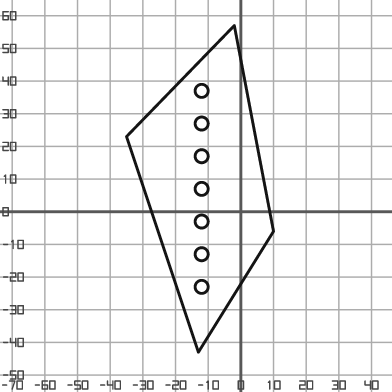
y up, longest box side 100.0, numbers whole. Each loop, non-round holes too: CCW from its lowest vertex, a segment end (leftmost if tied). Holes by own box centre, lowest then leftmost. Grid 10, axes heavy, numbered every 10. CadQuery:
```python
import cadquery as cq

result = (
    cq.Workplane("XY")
    .moveTo(-13.0, -43.0)
    .lineTo(10.0, -6.0)
    .lineTo(-2.0, 57.0)
    .lineTo(-35.0, 23.0)
    .close()
    .moveTo(-12.0, -23.0)
    .circle(2.0)
    .moveTo(-12.0, -13.0)
    .circle(2.0)
    .moveTo(-12.0, -3.0)
    .circle(2.0)
    .moveTo(-12.0, 7.0)
    .circle(2.0)
    .moveTo(-12.0, 17.0)
    .circle(2.0)
    .moveTo(-12.0, 27.0)
    .circle(2.0)
    .moveTo(-12.0, 37.0)
    .circle(2.0)
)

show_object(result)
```